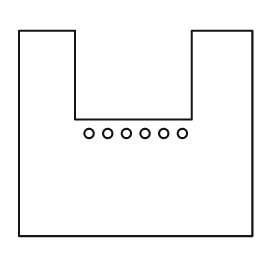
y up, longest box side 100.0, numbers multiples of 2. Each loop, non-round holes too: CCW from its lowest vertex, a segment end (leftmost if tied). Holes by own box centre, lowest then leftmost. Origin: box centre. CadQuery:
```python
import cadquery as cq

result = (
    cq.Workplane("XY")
    .moveTo(-50.0, -44.0)
    .lineTo(50.0, -44.0)
    .lineTo(50.0, 44.0)
    .lineTo(24.0, 44.0)
    .lineTo(24.0, 6.0)
    .lineTo(-26.0, 6.0)
    .lineTo(-26.0, 44.0)
    .lineTo(-50.0, 44.0)
    .close()
    .moveTo(-20.0, 0.0)
    .circle(2.0)
    .moveTo(-12.0, 0.0)
    .circle(2.0)
    .moveTo(-4.0, 0.0)
    .circle(2.0)
    .moveTo(4.0, 0.0)
    .circle(2.0)
    .moveTo(12.0, 0.0)
    .circle(2.0)
    .moveTo(20.0, 0.0)
    .circle(2.0)
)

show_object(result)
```